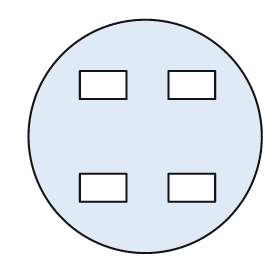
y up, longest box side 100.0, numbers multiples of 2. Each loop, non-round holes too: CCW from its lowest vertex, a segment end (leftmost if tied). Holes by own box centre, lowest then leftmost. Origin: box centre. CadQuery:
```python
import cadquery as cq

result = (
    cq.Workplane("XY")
    .moveTo(0.0, 0.0)
    .circle(50.0)
    .moveTo(-28.0, -28.0)
    .lineTo(-8.0, -28.0)
    .lineTo(-8.0, -16.0)
    .lineTo(-28.0, -16.0)
    .close()
    .moveTo(10.0, -28.0)
    .lineTo(30.0, -28.0)
    .lineTo(30.0, -16.0)
    .lineTo(10.0, -16.0)
    .close()
    .moveTo(-28.0, 16.0)
    .lineTo(-8.0, 16.0)
    .lineTo(-8.0, 28.0)
    .lineTo(-28.0, 28.0)
    .close()
    .moveTo(10.0, 16.0)
    .lineTo(30.0, 16.0)
    .lineTo(30.0, 28.0)
    .lineTo(10.0, 28.0)
    .close()
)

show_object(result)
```